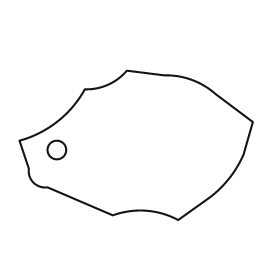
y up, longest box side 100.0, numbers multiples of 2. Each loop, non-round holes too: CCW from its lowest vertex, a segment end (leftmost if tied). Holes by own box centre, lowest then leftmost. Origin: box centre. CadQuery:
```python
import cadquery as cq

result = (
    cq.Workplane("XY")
    .moveTo(18.0, -32.0)
    .lineTo(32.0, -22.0)
    .threePointArc((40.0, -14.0), (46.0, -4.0))
    .lineTo(50.0, 10.0)
    .lineTo(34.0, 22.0)
    .threePointArc((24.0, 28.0), (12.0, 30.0))
    .lineTo(-4.0, 32.0)
    .threePointArc((-12.0, 26.0), (-22.0, 24.0))
    .threePointArc((-34.0, 10.0), (-50.0, 2.0))
    .lineTo(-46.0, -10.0)
    .threePointArc((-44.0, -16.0), (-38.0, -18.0))
    .lineTo(-10.0, -30.0)
    .threePointArc((4.0, -28.0), (18.0, -32.0))
    .close()
    .moveTo(-34.0, -2.0)
    .circle(4.0)
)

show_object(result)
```